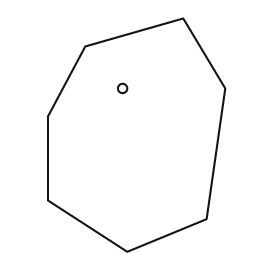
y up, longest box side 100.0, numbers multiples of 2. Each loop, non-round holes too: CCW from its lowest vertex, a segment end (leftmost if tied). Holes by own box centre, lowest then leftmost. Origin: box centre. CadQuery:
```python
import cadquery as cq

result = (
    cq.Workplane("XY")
    .moveTo(-4.0, -50.0)
    .lineTo(30.0, -36.0)
    .lineTo(38.0, 20.0)
    .lineTo(20.0, 50.0)
    .lineTo(-22.0, 38.0)
    .lineTo(-38.0, 8.0)
    .lineTo(-38.0, -28.0)
    .close()
    .moveTo(-6.0, 20.0)
    .circle(2.0)
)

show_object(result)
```